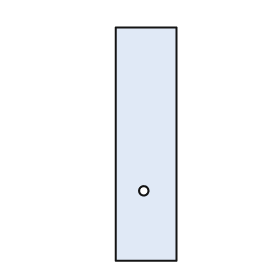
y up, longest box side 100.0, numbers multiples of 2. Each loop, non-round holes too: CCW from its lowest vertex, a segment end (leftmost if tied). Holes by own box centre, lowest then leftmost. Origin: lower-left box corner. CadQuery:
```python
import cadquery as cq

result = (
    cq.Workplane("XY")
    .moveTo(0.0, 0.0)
    .lineTo(26.0, 0.0)
    .lineTo(26.0, 100.0)
    .lineTo(0.0, 100.0)
    .close()
    .moveTo(12.0, 30.0)
    .circle(2.0)
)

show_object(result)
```